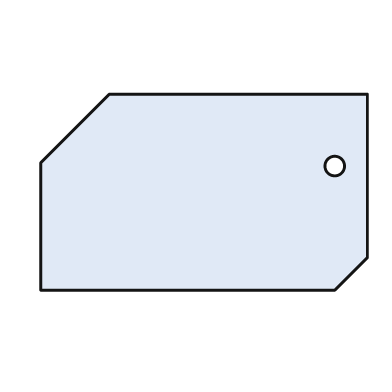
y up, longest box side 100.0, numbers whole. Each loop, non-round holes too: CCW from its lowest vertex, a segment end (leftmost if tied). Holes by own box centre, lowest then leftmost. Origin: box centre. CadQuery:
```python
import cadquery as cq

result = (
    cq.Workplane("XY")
    .moveTo(-50.0, -30.0)
    .lineTo(40.0, -30.0)
    .lineTo(50.0, -20.0)
    .lineTo(50.0, 30.0)
    .lineTo(-29.0, 30.0)
    .lineTo(-50.0, 9.0)
    .close()
    .moveTo(40.0, 8.0)
    .circle(3.0)
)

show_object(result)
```